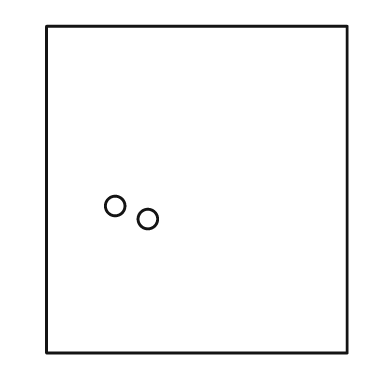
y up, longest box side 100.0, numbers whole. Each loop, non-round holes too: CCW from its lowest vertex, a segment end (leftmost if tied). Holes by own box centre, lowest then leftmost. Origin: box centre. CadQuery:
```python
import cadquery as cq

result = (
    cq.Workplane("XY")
    .moveTo(-46.0, -50.0)
    .lineTo(46.0, -50.0)
    .lineTo(46.0, 50.0)
    .lineTo(-46.0, 50.0)
    .close()
    .moveTo(-15.0, -9.0)
    .circle(3.0)
    .moveTo(-25.0, -5.0)
    .circle(3.0)
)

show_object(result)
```